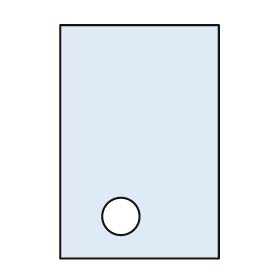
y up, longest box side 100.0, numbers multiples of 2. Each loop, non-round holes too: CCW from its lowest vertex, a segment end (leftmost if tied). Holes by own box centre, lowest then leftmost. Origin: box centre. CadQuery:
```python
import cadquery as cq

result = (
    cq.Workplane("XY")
    .moveTo(-34.0, -50.0)
    .lineTo(34.0, -50.0)
    .lineTo(34.0, 50.0)
    .lineTo(-34.0, 50.0)
    .close()
    .moveTo(-8.0, -32.0)
    .circle(8.0)
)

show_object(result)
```